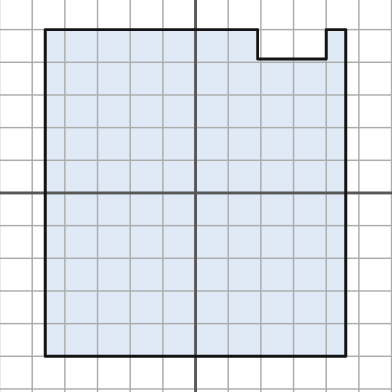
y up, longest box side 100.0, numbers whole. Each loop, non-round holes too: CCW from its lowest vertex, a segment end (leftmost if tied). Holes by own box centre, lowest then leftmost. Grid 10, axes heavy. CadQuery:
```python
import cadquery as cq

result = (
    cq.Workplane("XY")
    .moveTo(-46.0, -50.0)
    .lineTo(46.0, -50.0)
    .lineTo(46.0, 50.0)
    .lineTo(40.0, 50.0)
    .lineTo(40.0, 41.0)
    .lineTo(19.0, 41.0)
    .lineTo(19.0, 50.0)
    .lineTo(-46.0, 50.0)
    .close()
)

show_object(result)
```